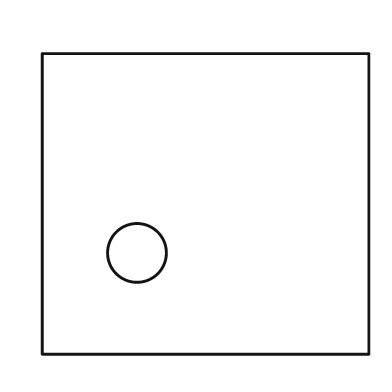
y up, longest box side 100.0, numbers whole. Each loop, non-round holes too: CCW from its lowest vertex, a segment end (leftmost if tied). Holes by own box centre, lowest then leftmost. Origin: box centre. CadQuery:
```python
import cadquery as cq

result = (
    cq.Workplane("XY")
    .moveTo(-50.0, -46.0)
    .lineTo(50.0, -46.0)
    .lineTo(50.0, 46.0)
    .lineTo(-50.0, 46.0)
    .close()
    .moveTo(-21.0, -15.0)
    .circle(9.0)
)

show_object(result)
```